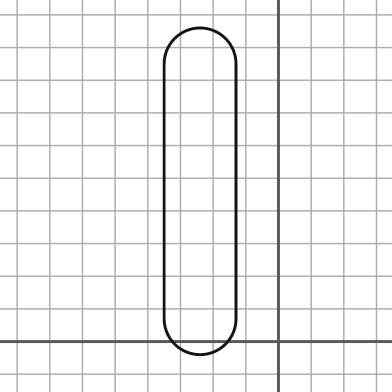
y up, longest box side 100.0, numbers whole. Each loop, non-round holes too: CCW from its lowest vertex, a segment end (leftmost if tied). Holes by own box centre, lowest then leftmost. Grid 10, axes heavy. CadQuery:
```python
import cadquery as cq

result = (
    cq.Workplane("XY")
    .moveTo(-35.0, 7.0)
    .threePointArc((-24.0, -4.0), (-13.0, 7.0))
    .lineTo(-13.0, 85.0)
    .threePointArc((-24.0, 96.0), (-35.0, 85.0))
    .close()
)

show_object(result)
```